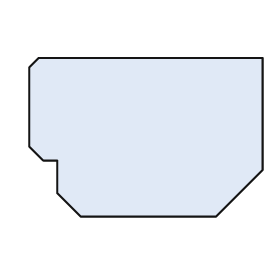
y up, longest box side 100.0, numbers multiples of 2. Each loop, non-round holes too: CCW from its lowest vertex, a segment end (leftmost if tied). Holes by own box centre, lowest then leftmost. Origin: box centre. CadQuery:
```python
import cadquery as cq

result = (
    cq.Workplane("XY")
    .moveTo(-28.0, -34.0)
    .lineTo(30.0, -34.0)
    .lineTo(50.0, -14.0)
    .lineTo(50.0, 34.0)
    .lineTo(-46.0, 34.0)
    .lineTo(-50.0, 30.0)
    .lineTo(-50.0, -4.0)
    .lineTo(-44.0, -10.0)
    .lineTo(-38.0, -10.0)
    .lineTo(-38.0, -24.0)
    .close()
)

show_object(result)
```